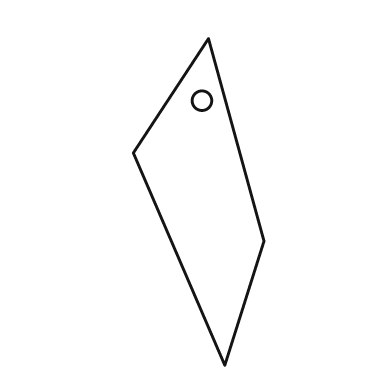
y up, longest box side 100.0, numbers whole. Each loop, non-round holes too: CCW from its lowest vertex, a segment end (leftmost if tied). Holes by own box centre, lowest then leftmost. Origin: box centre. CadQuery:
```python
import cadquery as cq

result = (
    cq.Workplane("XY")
    .moveTo(8.0, -50.0)
    .lineTo(20.0, -12.0)
    .lineTo(3.0, 50.0)
    .lineTo(-20.0, 15.0)
    .close()
    .moveTo(1.0, 31.0)
    .circle(3.0)
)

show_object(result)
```